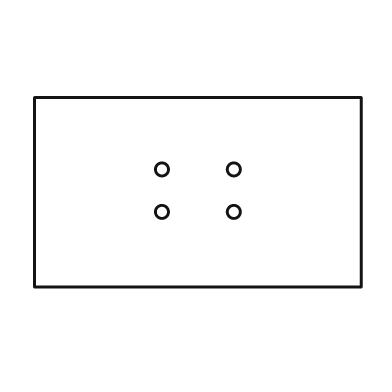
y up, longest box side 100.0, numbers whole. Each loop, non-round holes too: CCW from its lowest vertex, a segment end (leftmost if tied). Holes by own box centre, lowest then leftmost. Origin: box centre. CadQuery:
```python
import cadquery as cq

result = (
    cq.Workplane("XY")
    .moveTo(-50.0, -29.0)
    .lineTo(50.0, -29.0)
    .lineTo(50.0, 29.0)
    .lineTo(-50.0, 29.0)
    .close()
    .moveTo(-11.0, -6.0)
    .circle(2.0)
    .moveTo(11.0, -6.0)
    .circle(2.0)
    .moveTo(-11.0, 7.0)
    .circle(2.0)
    .moveTo(11.0, 7.0)
    .circle(2.0)
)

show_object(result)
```